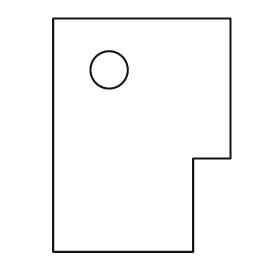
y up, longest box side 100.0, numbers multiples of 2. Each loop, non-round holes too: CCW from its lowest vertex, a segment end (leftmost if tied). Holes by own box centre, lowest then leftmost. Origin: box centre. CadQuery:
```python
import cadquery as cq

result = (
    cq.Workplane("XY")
    .moveTo(-38.0, -50.0)
    .lineTo(22.0, -50.0)
    .lineTo(22.0, -10.0)
    .lineTo(38.0, -10.0)
    .lineTo(38.0, 50.0)
    .lineTo(-38.0, 50.0)
    .close()
    .moveTo(-14.0, 28.0)
    .circle(8.0)
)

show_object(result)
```